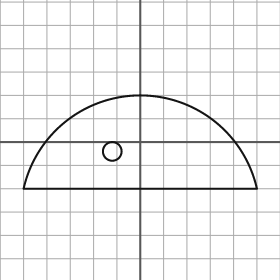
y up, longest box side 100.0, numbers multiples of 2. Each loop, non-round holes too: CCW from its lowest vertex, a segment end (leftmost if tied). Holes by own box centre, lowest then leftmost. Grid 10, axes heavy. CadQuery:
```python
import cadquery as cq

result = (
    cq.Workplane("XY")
    .moveTo(-50.0, -20.0)
    .lineTo(50.0, -20.0)
    .threePointArc((0.0, 20.0), (-50.0, -20.0))
    .close()
    .moveTo(-12.0, -4.0)
    .circle(4.0)
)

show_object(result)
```